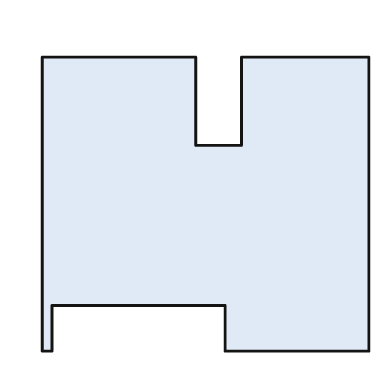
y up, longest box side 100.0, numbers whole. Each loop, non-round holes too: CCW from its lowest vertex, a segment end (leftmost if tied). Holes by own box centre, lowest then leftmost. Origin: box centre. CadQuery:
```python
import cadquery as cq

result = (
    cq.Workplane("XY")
    .moveTo(-50.0, -45.0)
    .lineTo(-47.0, -45.0)
    .lineTo(-47.0, -31.0)
    .lineTo(6.0, -31.0)
    .lineTo(6.0, -45.0)
    .lineTo(50.0, -45.0)
    .lineTo(50.0, 45.0)
    .lineTo(11.0, 45.0)
    .lineTo(11.0, 18.0)
    .lineTo(-3.0, 18.0)
    .lineTo(-3.0, 45.0)
    .lineTo(-50.0, 45.0)
    .close()
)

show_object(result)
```